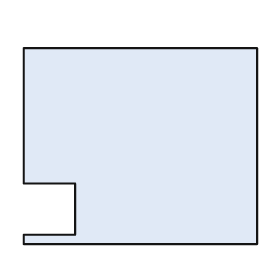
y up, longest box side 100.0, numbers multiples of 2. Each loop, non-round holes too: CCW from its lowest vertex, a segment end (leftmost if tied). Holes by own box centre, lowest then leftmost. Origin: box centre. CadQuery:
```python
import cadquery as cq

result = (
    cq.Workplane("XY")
    .moveTo(-50.0, -42.0)
    .lineTo(50.0, -42.0)
    .lineTo(50.0, 42.0)
    .lineTo(-50.0, 42.0)
    .lineTo(-50.0, -16.0)
    .lineTo(-28.0, -16.0)
    .lineTo(-28.0, -38.0)
    .lineTo(-50.0, -38.0)
    .close()
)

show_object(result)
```